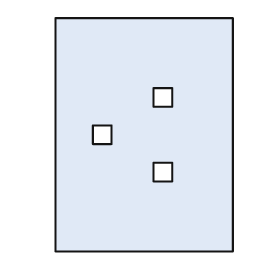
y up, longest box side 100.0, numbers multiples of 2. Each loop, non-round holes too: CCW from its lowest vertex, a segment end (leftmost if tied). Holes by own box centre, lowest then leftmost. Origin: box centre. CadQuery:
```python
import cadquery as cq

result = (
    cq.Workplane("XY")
    .moveTo(-38.0, -50.0)
    .lineTo(38.0, -50.0)
    .lineTo(38.0, 50.0)
    .lineTo(-38.0, 50.0)
    .close()
    .moveTo(4.0, -20.0)
    .lineTo(12.0, -20.0)
    .lineTo(12.0, -12.0)
    .lineTo(4.0, -12.0)
    .close()
    .moveTo(-22.0, -4.0)
    .lineTo(-14.0, -4.0)
    .lineTo(-14.0, 4.0)
    .lineTo(-22.0, 4.0)
    .close()
    .moveTo(4.0, 12.0)
    .lineTo(12.0, 12.0)
    .lineTo(12.0, 20.0)
    .lineTo(4.0, 20.0)
    .close()
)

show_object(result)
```